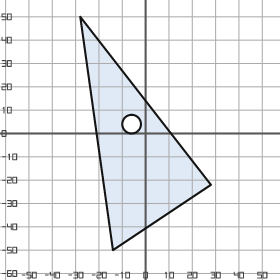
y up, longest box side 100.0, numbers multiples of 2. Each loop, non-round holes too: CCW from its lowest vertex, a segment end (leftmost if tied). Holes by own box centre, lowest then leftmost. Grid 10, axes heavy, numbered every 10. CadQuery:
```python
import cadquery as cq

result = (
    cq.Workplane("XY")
    .moveTo(-14.0, -50.0)
    .lineTo(28.0, -22.0)
    .lineTo(-28.0, 50.0)
    .close()
    .moveTo(-6.0, 4.0)
    .circle(4.0)
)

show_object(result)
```